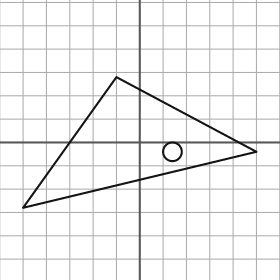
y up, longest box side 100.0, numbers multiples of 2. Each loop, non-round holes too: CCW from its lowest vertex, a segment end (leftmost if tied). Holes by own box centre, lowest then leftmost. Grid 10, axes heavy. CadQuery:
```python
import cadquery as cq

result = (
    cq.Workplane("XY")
    .moveTo(-50.0, -28.0)
    .lineTo(50.0, -4.0)
    .lineTo(-10.0, 28.0)
    .close()
    .moveTo(14.0, -4.0)
    .circle(4.0)
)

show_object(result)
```